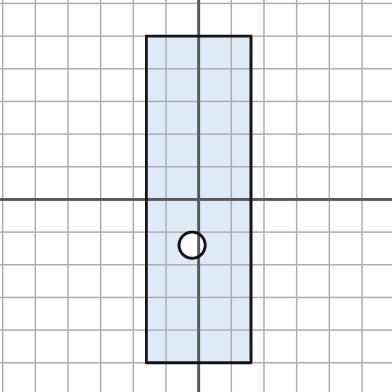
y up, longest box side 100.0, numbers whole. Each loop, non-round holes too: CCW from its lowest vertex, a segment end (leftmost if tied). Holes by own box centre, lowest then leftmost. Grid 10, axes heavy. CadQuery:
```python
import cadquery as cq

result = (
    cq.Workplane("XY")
    .moveTo(-16.0, -50.0)
    .lineTo(16.0, -50.0)
    .lineTo(16.0, 50.0)
    .lineTo(-16.0, 50.0)
    .close()
    .moveTo(-2.0, -14.0)
    .circle(4.0)
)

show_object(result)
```